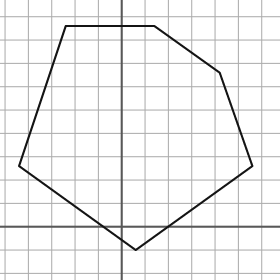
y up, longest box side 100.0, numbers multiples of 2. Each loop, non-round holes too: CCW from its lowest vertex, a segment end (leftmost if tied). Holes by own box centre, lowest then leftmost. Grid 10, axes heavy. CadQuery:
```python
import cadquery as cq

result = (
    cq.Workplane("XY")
    .moveTo(6.0, -10.0)
    .lineTo(56.0, 26.0)
    .lineTo(42.0, 66.0)
    .lineTo(14.0, 86.0)
    .lineTo(-24.0, 86.0)
    .lineTo(-44.0, 26.0)
    .close()
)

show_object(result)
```